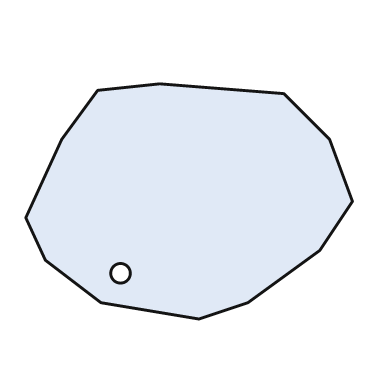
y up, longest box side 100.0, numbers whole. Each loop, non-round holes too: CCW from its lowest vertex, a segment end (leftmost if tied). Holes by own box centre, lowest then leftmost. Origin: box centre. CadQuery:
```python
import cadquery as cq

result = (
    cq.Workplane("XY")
    .moveTo(3.0, -36.0)
    .lineTo(18.0, -31.0)
    .lineTo(40.0, -15.0)
    .lineTo(50.0, 0.0)
    .lineTo(43.0, 19.0)
    .lineTo(29.0, 33.0)
    .lineTo(-9.0, 36.0)
    .lineTo(-28.0, 34.0)
    .lineTo(-39.0, 19.0)
    .lineTo(-50.0, -5.0)
    .lineTo(-44.0, -18.0)
    .lineTo(-27.0, -31.0)
    .close()
    .moveTo(-21.0, -22.0)
    .circle(3.0)
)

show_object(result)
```